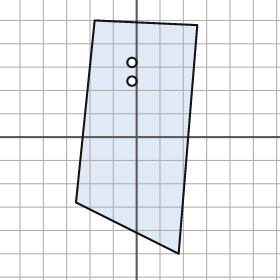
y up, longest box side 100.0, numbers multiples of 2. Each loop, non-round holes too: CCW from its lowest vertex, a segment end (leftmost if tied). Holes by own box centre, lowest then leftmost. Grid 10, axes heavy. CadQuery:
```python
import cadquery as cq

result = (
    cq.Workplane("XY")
    .moveTo(18.0, -50.0)
    .lineTo(26.0, 48.0)
    .lineTo(-18.0, 50.0)
    .lineTo(-26.0, -28.0)
    .close()
    .moveTo(-2.0, 24.0)
    .circle(2.0)
    .moveTo(-2.0, 32.0)
    .circle(2.0)
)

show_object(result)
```